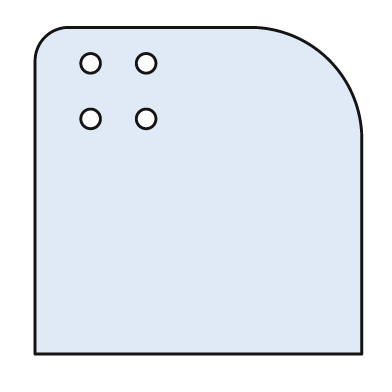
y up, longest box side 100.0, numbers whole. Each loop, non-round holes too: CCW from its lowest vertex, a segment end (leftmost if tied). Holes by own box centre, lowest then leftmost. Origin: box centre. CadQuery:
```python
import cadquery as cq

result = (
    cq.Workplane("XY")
    .moveTo(-50.0, -50.0)
    .lineTo(50.0, -50.0)
    .lineTo(50.0, 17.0)
    .threePointArc((40.0, 40.0), (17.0, 50.0))
    .lineTo(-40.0, 50.0)
    .threePointArc((-47.0, 47.0), (-50.0, 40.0))
    .close()
    .moveTo(-33.0, 22.0)
    .circle(3.0)
    .moveTo(-16.0, 22.0)
    .circle(3.0)
    .moveTo(-33.0, 39.0)
    .circle(3.0)
    .moveTo(-16.0, 39.0)
    .circle(3.0)
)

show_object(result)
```